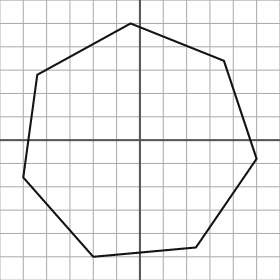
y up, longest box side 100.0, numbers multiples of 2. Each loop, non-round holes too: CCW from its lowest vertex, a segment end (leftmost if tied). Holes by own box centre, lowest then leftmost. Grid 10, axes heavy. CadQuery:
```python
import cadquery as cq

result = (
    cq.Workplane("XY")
    .moveTo(-20.0, -50.0)
    .lineTo(24.0, -46.0)
    .lineTo(50.0, -8.0)
    .lineTo(36.0, 34.0)
    .lineTo(-4.0, 50.0)
    .lineTo(-44.0, 28.0)
    .lineTo(-50.0, -16.0)
    .close()
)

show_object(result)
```